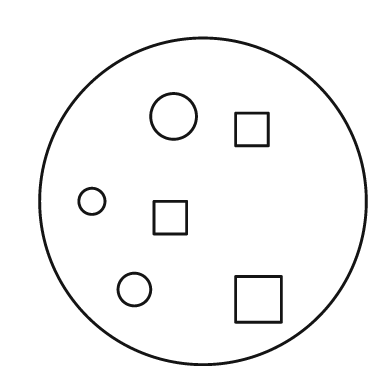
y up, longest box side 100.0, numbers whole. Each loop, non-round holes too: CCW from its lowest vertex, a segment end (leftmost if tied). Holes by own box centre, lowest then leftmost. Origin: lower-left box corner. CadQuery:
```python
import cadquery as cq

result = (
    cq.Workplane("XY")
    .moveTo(50.0, 50.0)
    .circle(50.0)
    .moveTo(60.0, 13.0)
    .lineTo(74.0, 13.0)
    .lineTo(74.0, 27.0)
    .lineTo(60.0, 27.0)
    .close()
    .moveTo(29.0, 23.0)
    .circle(5.0)
    .moveTo(35.0, 40.0)
    .lineTo(45.0, 40.0)
    .lineTo(45.0, 50.0)
    .lineTo(35.0, 50.0)
    .close()
    .moveTo(16.0, 50.0)
    .circle(4.0)
    .moveTo(60.0, 67.0)
    .lineTo(70.0, 67.0)
    .lineTo(70.0, 77.0)
    .lineTo(60.0, 77.0)
    .close()
    .moveTo(41.0, 76.0)
    .circle(7.0)
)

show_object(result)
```